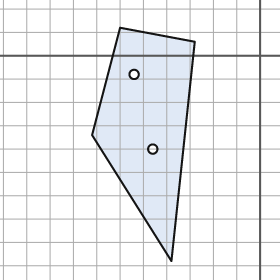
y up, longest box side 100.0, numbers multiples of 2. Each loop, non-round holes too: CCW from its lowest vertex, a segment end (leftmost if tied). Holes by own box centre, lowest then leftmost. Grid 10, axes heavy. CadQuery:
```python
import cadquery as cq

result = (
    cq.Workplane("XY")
    .moveTo(-38.0, -88.0)
    .lineTo(-28.0, 6.0)
    .lineTo(-60.0, 12.0)
    .lineTo(-72.0, -34.0)
    .close()
    .moveTo(-46.0, -40.0)
    .circle(2.0)
    .moveTo(-54.0, -8.0)
    .circle(2.0)
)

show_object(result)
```